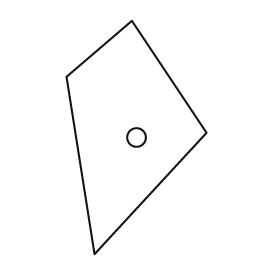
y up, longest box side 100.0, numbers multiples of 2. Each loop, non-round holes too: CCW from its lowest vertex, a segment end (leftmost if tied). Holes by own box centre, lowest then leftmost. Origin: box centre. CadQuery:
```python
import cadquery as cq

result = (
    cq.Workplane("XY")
    .moveTo(-18.0, -50.0)
    .lineTo(30.0, 2.0)
    .lineTo(-2.0, 50.0)
    .lineTo(-30.0, 26.0)
    .close()
    .moveTo(0.0, 0.0)
    .circle(4.0)
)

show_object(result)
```